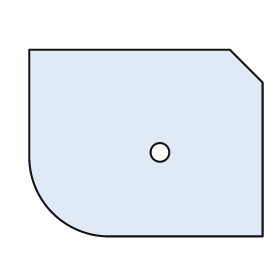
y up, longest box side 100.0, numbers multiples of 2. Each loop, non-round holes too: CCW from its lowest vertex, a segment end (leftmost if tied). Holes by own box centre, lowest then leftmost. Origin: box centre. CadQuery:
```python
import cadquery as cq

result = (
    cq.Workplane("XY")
    .moveTo(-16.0, -40.0)
    .lineTo(50.0, -40.0)
    .lineTo(50.0, 26.0)
    .lineTo(36.0, 40.0)
    .lineTo(-50.0, 40.0)
    .lineTo(-50.0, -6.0)
    .threePointArc((-40.0, -30.0), (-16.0, -40.0))
    .close()
    .moveTo(6.0, -4.0)
    .circle(4.0)
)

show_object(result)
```